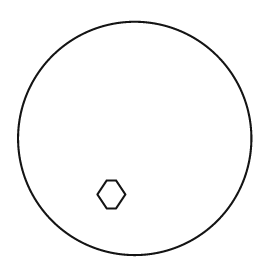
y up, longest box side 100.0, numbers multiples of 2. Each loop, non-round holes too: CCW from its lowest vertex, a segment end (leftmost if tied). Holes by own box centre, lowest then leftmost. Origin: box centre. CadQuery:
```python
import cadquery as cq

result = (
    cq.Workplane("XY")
    .moveTo(0.0, 0.0)
    .circle(50.0)
    .moveTo(-12.0, -30.0)
    .lineTo(-8.0, -30.0)
    .lineTo(-4.0, -24.0)
    .lineTo(-8.0, -18.0)
    .lineTo(-12.0, -18.0)
    .lineTo(-16.0, -24.0)
    .close()
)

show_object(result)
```